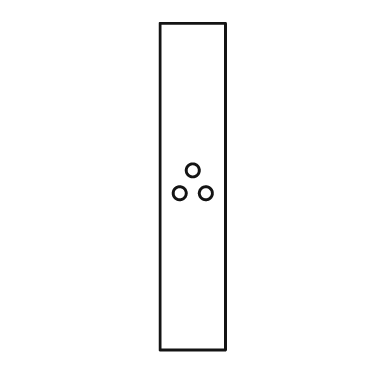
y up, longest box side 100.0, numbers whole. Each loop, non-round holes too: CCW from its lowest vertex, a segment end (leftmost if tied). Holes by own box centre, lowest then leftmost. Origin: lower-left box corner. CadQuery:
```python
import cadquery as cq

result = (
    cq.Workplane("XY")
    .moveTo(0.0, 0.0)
    .lineTo(20.0, 0.0)
    .lineTo(20.0, 100.0)
    .lineTo(0.0, 100.0)
    .close()
    .moveTo(6.0, 48.0)
    .circle(2.0)
    .moveTo(14.0, 48.0)
    .circle(2.0)
    .moveTo(10.0, 55.0)
    .circle(2.0)
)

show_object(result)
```